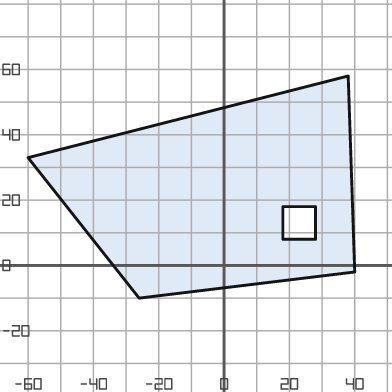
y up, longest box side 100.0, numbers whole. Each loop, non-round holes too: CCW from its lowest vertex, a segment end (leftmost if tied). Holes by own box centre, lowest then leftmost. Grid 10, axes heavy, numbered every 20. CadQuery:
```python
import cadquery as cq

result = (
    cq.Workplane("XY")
    .moveTo(-26.0, -10.0)
    .lineTo(40.0, -2.0)
    .lineTo(38.0, 58.0)
    .lineTo(-60.0, 33.0)
    .close()
    .moveTo(18.0, 8.0)
    .lineTo(28.0, 8.0)
    .lineTo(28.0, 18.0)
    .lineTo(18.0, 18.0)
    .close()
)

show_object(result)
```